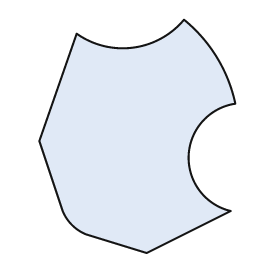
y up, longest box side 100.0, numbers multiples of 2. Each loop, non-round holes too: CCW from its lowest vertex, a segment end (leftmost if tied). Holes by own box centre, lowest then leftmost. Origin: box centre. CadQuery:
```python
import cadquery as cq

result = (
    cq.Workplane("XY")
    .moveTo(4.0, -50.0)
    .lineTo(40.0, -32.0)
    .threePointArc((22.0, -8.0), (42.0, 14.0))
    .threePointArc((34.0, 34.0), (20.0, 50.0))
    .threePointArc((-2.0, 38.0), (-26.0, 44.0))
    .lineTo(-42.0, -2.0)
    .lineTo(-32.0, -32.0)
    .threePointArc((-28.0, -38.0), (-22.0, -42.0))
    .close()
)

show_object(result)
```